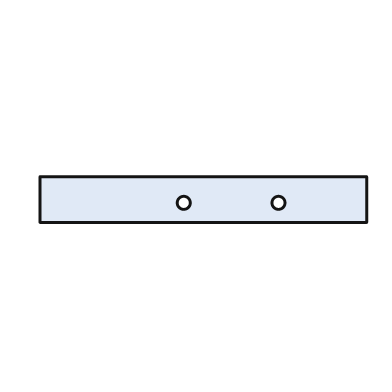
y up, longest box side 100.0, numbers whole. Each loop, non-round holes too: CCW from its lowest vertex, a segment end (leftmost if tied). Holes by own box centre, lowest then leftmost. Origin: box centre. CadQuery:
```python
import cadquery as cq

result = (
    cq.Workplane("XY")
    .moveTo(-50.0, -7.0)
    .lineTo(50.0, -7.0)
    .lineTo(50.0, 7.0)
    .lineTo(-50.0, 7.0)
    .close()
    .moveTo(-6.0, -1.0)
    .circle(2.0)
    .moveTo(23.0, -1.0)
    .circle(2.0)
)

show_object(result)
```